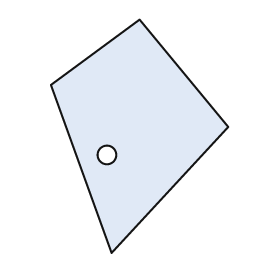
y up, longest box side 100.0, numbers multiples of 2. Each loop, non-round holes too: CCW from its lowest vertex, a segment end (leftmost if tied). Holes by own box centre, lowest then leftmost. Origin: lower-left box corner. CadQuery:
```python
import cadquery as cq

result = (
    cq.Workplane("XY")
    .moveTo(26.0, 0.0)
    .lineTo(76.0, 54.0)
    .lineTo(38.0, 100.0)
    .lineTo(0.0, 72.0)
    .close()
    .moveTo(24.0, 42.0)
    .circle(4.0)
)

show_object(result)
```